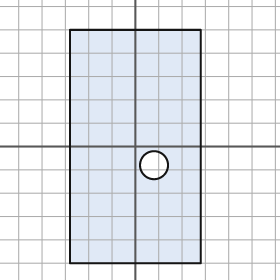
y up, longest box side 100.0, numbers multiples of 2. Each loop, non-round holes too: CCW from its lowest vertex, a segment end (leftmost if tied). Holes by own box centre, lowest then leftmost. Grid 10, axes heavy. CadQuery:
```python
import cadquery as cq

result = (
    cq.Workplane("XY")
    .moveTo(-28.0, -50.0)
    .lineTo(28.0, -50.0)
    .lineTo(28.0, 50.0)
    .lineTo(-28.0, 50.0)
    .close()
    .moveTo(8.0, -8.0)
    .circle(6.0)
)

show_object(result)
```